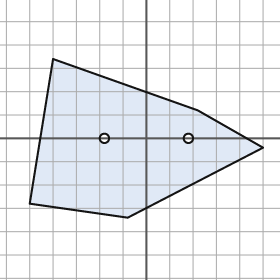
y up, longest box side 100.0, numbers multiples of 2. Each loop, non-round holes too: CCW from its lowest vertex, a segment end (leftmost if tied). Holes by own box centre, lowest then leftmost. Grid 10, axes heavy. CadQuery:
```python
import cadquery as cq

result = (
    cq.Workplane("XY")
    .moveTo(-8.0, -34.0)
    .lineTo(50.0, -4.0)
    .lineTo(22.0, 12.0)
    .lineTo(-40.0, 34.0)
    .lineTo(-50.0, -28.0)
    .close()
    .moveTo(-18.0, 0.0)
    .circle(2.0)
    .moveTo(18.0, 0.0)
    .circle(2.0)
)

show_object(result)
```